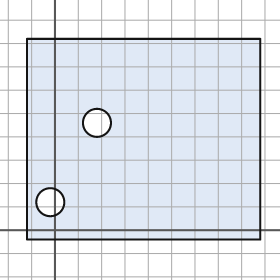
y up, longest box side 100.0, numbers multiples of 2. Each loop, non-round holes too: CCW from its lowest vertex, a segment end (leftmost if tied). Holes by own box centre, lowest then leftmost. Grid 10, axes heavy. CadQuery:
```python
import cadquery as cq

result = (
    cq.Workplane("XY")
    .moveTo(-12.0, -4.0)
    .lineTo(88.0, -4.0)
    .lineTo(88.0, 82.0)
    .lineTo(-12.0, 82.0)
    .close()
    .moveTo(-2.0, 12.0)
    .circle(6.0)
    .moveTo(18.0, 46.0)
    .circle(6.0)
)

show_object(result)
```